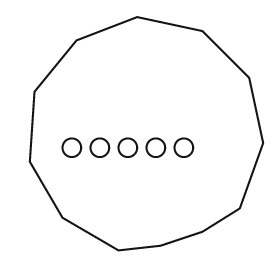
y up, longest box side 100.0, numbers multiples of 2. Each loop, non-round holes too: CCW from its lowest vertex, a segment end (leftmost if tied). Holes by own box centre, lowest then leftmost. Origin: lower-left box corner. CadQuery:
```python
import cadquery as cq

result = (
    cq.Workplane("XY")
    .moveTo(38.0, 0.0)
    .lineTo(56.0, 2.0)
    .lineTo(74.0, 8.0)
    .lineTo(90.0, 18.0)
    .lineTo(100.0, 46.0)
    .lineTo(94.0, 74.0)
    .lineTo(74.0, 94.0)
    .lineTo(46.0, 100.0)
    .lineTo(20.0, 90.0)
    .lineTo(2.0, 68.0)
    .lineTo(0.0, 38.0)
    .lineTo(14.0, 14.0)
    .close()
    .moveTo(18.0, 44.0)
    .circle(4.0)
    .moveTo(30.0, 44.0)
    .circle(4.0)
    .moveTo(42.0, 44.0)
    .circle(4.0)
    .moveTo(54.0, 44.0)
    .circle(4.0)
    .moveTo(66.0, 44.0)
    .circle(4.0)
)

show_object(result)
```